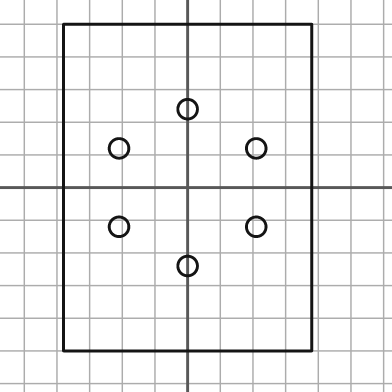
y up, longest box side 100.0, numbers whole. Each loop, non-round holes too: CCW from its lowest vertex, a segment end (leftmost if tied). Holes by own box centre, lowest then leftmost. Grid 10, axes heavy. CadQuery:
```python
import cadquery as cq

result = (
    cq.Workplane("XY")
    .moveTo(-38.0, -50.0)
    .lineTo(38.0, -50.0)
    .lineTo(38.0, 50.0)
    .lineTo(-38.0, 50.0)
    .close()
    .moveTo(0.0, -24.0)
    .circle(3.0)
    .moveTo(-21.0, -12.0)
    .circle(3.0)
    .moveTo(21.0, -12.0)
    .circle(3.0)
    .moveTo(-21.0, 12.0)
    .circle(3.0)
    .moveTo(21.0, 12.0)
    .circle(3.0)
    .moveTo(0.0, 24.0)
    .circle(3.0)
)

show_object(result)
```